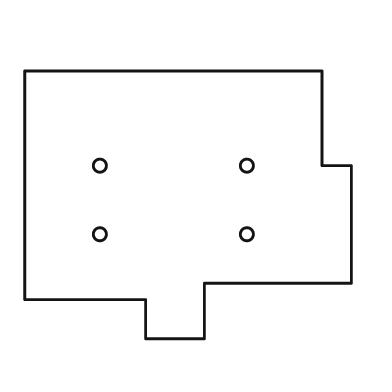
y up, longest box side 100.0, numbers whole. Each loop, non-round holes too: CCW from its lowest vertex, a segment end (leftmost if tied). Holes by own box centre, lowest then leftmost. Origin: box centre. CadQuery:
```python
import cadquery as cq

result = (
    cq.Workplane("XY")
    .moveTo(-13.0, -41.0)
    .lineTo(5.0, -41.0)
    .lineTo(5.0, -24.0)
    .lineTo(50.0, -24.0)
    .lineTo(50.0, 12.0)
    .lineTo(41.0, 12.0)
    .lineTo(41.0, 41.0)
    .lineTo(-50.0, 41.0)
    .lineTo(-50.0, -29.0)
    .lineTo(-13.0, -29.0)
    .close()
    .moveTo(-27.0, -9.0)
    .circle(2.0)
    .moveTo(18.0, -9.0)
    .circle(2.0)
    .moveTo(-27.0, 12.0)
    .circle(2.0)
    .moveTo(18.0, 12.0)
    .circle(2.0)
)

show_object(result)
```